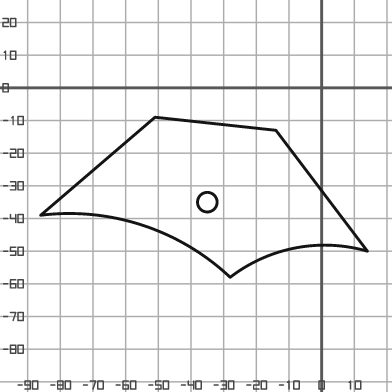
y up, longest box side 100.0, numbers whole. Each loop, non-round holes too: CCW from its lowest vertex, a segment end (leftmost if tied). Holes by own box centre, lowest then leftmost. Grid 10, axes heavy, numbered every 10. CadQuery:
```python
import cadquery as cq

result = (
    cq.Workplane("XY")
    .moveTo(-28.0, -58.0)
    .threePointArc((-8.0, -49.0), (14.0, -50.0))
    .lineTo(-14.0, -13.0)
    .lineTo(-51.0, -9.0)
    .lineTo(-86.0, -39.0)
    .threePointArc((-55.0, -42.0), (-28.0, -58.0))
    .close()
    .moveTo(-35.0, -35.0)
    .circle(3.0)
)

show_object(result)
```